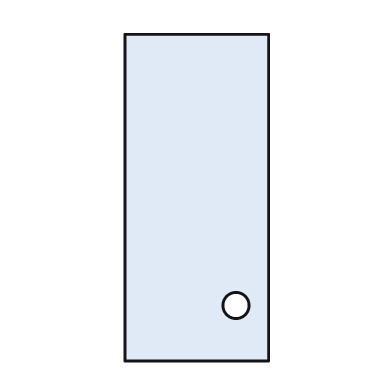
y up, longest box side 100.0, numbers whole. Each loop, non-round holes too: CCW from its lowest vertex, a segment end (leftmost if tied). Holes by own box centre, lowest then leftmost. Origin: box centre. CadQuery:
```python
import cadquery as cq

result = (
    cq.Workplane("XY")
    .moveTo(-22.0, -50.0)
    .lineTo(22.0, -50.0)
    .lineTo(22.0, 50.0)
    .lineTo(-22.0, 50.0)
    .close()
    .moveTo(12.0, -33.0)
    .circle(4.0)
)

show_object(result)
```